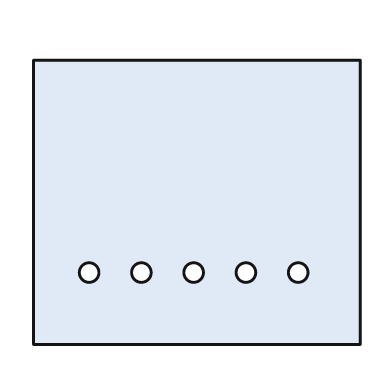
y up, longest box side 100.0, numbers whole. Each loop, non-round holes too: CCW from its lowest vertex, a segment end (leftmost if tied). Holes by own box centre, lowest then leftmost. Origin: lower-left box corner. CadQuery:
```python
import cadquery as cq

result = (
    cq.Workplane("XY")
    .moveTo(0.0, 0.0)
    .lineTo(100.0, 0.0)
    .lineTo(100.0, 87.0)
    .lineTo(0.0, 87.0)
    .close()
    .moveTo(17.0, 22.0)
    .circle(3.0)
    .moveTo(33.0, 22.0)
    .circle(3.0)
    .moveTo(49.0, 22.0)
    .circle(3.0)
    .moveTo(65.0, 22.0)
    .circle(3.0)
    .moveTo(81.0, 22.0)
    .circle(3.0)
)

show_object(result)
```